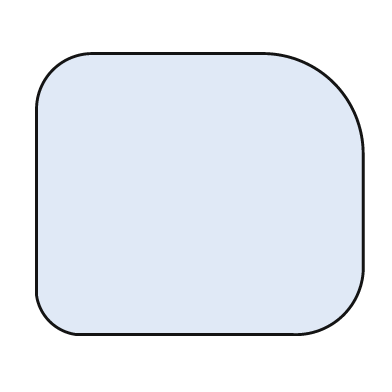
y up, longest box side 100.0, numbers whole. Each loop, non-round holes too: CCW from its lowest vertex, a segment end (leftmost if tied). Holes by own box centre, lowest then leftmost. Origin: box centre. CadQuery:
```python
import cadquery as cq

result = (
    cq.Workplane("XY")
    .moveTo(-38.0, -43.0)
    .lineTo(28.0, -43.0)
    .threePointArc((44.0, -37.0), (50.0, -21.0))
    .lineTo(50.0, 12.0)
    .threePointArc((41.0, 34.0), (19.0, 43.0))
    .lineTo(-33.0, 43.0)
    .threePointArc((-45.0, 38.0), (-50.0, 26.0))
    .lineTo(-50.0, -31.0)
    .threePointArc((-46.0, -39.0), (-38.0, -43.0))
    .close()
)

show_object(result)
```